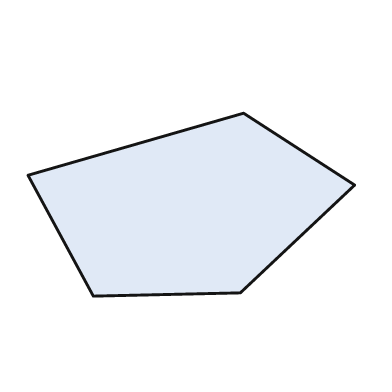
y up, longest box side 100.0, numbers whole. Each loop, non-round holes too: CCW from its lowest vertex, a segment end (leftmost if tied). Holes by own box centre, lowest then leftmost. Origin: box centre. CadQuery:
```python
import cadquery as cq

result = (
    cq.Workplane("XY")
    .moveTo(-30.0, -28.0)
    .lineTo(15.0, -27.0)
    .lineTo(50.0, 6.0)
    .lineTo(16.0, 28.0)
    .lineTo(-50.0, 9.0)
    .close()
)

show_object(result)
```